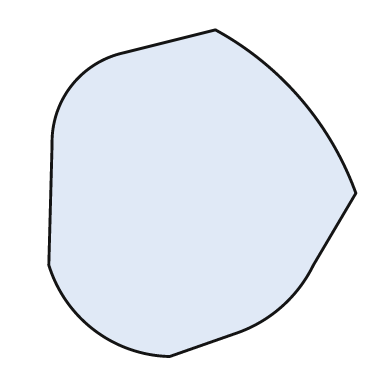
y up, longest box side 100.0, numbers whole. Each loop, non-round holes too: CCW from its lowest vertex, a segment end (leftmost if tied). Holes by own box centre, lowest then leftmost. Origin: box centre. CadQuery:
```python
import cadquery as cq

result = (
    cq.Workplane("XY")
    .moveTo(-10.0, -50.0)
    .lineTo(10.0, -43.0)
    .threePointArc((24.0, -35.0), (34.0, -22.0))
    .lineTo(47.0, 0.0)
    .threePointArc((30.0, 29.0), (4.0, 50.0))
    .lineTo(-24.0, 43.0)
    .threePointArc((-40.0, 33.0), (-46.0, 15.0))
    .lineTo(-47.0, -22.0)
    .threePointArc((-33.0, -42.0), (-10.0, -50.0))
    .close()
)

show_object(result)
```